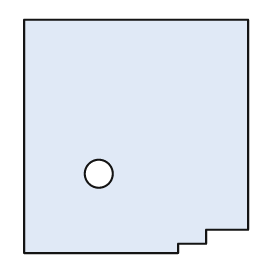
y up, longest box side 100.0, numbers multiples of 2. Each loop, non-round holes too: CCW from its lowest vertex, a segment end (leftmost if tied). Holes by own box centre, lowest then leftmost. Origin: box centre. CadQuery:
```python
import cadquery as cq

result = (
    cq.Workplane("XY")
    .moveTo(-48.0, -50.0)
    .lineTo(18.0, -50.0)
    .lineTo(18.0, -46.0)
    .lineTo(30.0, -46.0)
    .lineTo(30.0, -40.0)
    .lineTo(48.0, -40.0)
    .lineTo(48.0, 50.0)
    .lineTo(-48.0, 50.0)
    .close()
    .moveTo(-16.0, -16.0)
    .circle(6.0)
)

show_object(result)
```